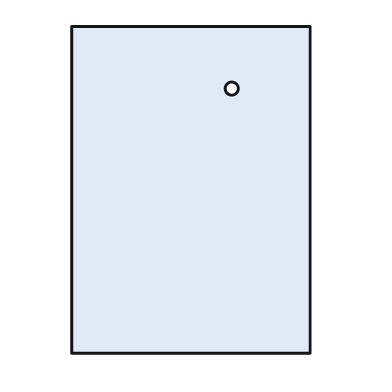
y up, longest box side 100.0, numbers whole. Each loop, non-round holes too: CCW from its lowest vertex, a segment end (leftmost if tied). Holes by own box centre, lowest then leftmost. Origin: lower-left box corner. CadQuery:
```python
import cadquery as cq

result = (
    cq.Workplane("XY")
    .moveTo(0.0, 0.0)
    .lineTo(73.0, 0.0)
    .lineTo(73.0, 100.0)
    .lineTo(0.0, 100.0)
    .close()
    .moveTo(49.0, 81.0)
    .circle(2.0)
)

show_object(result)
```